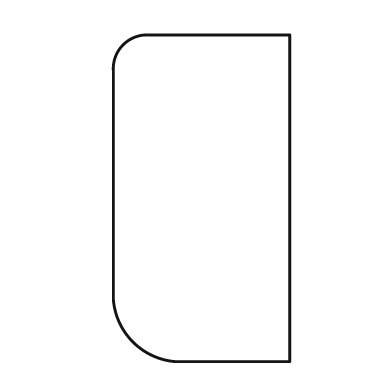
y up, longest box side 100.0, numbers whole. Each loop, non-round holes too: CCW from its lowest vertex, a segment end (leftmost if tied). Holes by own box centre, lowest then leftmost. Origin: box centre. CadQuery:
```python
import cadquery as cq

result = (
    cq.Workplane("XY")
    .moveTo(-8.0, -50.0)
    .lineTo(27.0, -50.0)
    .lineTo(27.0, 50.0)
    .lineTo(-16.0, 50.0)
    .threePointArc((-24.0, 47.0), (-27.0, 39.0))
    .lineTo(-27.0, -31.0)
    .threePointArc((-21.0, -44.0), (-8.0, -50.0))
    .close()
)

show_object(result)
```